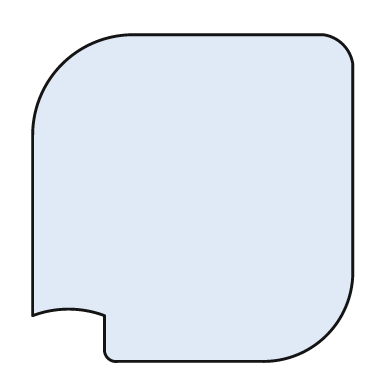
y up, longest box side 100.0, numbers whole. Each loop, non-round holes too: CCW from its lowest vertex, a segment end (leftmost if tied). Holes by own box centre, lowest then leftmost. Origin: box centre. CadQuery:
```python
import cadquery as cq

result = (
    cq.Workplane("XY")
    .moveTo(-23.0, -50.0)
    .lineTo(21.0, -50.0)
    .threePointArc((41.0, -42.0), (49.0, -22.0))
    .lineTo(49.0, 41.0)
    .threePointArc((46.0, 47.0), (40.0, 50.0))
    .lineTo(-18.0, 50.0)
    .threePointArc((-40.0, 41.0), (-49.0, 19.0))
    .lineTo(-49.0, -36.0)
    .threePointArc((-38.0, -34.0), (-27.0, -36.0))
    .lineTo(-27.0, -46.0)
    .threePointArc((-26.0, -49.0), (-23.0, -50.0))
    .close()
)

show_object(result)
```